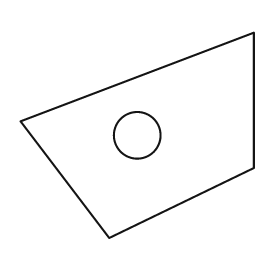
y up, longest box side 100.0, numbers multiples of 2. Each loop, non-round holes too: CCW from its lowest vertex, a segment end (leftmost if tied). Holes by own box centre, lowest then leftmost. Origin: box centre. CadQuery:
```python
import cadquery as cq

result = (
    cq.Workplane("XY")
    .moveTo(-12.0, -44.0)
    .lineTo(50.0, -14.0)
    .lineTo(50.0, 44.0)
    .lineTo(-50.0, 6.0)
    .close()
    .moveTo(0.0, 0.0)
    .circle(10.0)
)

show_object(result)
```